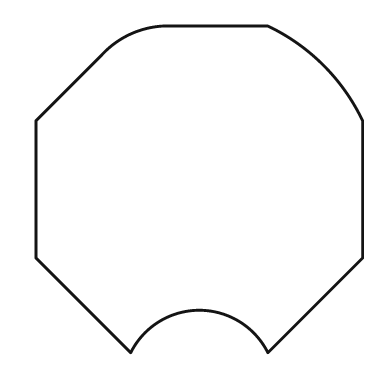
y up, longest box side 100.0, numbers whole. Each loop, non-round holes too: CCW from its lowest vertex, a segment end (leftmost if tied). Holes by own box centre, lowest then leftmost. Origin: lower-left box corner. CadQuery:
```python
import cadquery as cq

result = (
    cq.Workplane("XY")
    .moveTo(29.0, 0.0)
    .threePointArc((50.0, 13.0), (71.0, 0.0))
    .lineTo(100.0, 29.0)
    .lineTo(100.0, 71.0)
    .threePointArc((88.0, 88.0), (71.0, 100.0))
    .lineTo(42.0, 100.0)
    .threePointArc((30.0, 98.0), (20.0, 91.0))
    .lineTo(0.0, 71.0)
    .lineTo(0.0, 29.0)
    .close()
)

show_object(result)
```